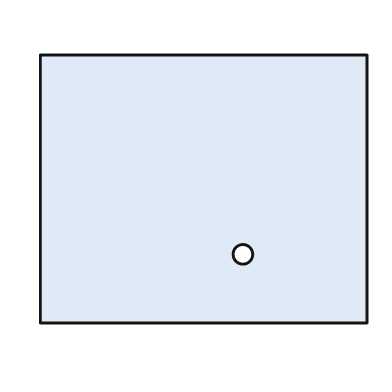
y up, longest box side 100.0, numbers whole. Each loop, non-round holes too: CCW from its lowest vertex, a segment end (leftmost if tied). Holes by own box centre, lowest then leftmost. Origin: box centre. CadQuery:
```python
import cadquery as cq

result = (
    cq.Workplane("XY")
    .moveTo(-50.0, -41.0)
    .lineTo(50.0, -41.0)
    .lineTo(50.0, 41.0)
    .lineTo(-50.0, 41.0)
    .close()
    .moveTo(12.0, -20.0)
    .circle(3.0)
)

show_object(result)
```